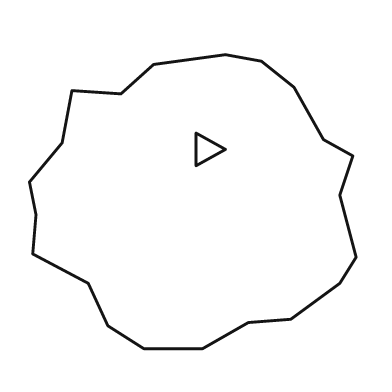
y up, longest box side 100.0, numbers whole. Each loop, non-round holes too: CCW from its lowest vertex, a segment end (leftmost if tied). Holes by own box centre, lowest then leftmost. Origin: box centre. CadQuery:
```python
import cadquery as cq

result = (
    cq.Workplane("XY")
    .moveTo(-15.0, -45.0)
    .lineTo(3.0, -45.0)
    .lineTo(17.0, -37.0)
    .lineTo(30.0, -36.0)
    .lineTo(45.0, -25.0)
    .lineTo(50.0, -17.0)
    .lineTo(45.0, 2.0)
    .lineTo(49.0, 14.0)
    .lineTo(40.0, 19.0)
    .lineTo(31.0, 35.0)
    .lineTo(21.0, 43.0)
    .lineTo(10.0, 45.0)
    .lineTo(-12.0, 42.0)
    .lineTo(-22.0, 33.0)
    .lineTo(-37.0, 34.0)
    .lineTo(-40.0, 18.0)
    .lineTo(-50.0, 6.0)
    .lineTo(-48.0, -4.0)
    .lineTo(-49.0, -16.0)
    .lineTo(-32.0, -25.0)
    .lineTo(-26.0, -38.0)
    .close()
    .moveTo(1.0, 11.0)
    .lineTo(10.0, 16.0)
    .lineTo(1.0, 21.0)
    .close()
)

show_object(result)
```